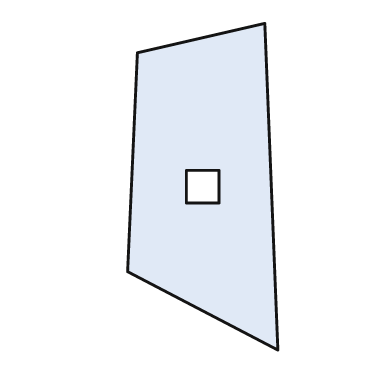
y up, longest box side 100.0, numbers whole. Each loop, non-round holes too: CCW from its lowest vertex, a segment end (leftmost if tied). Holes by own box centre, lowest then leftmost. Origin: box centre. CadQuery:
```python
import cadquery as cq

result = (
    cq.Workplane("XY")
    .moveTo(23.0, -50.0)
    .lineTo(19.0, 50.0)
    .lineTo(-20.0, 41.0)
    .lineTo(-23.0, -26.0)
    .close()
    .moveTo(-5.0, -5.0)
    .lineTo(5.0, -5.0)
    .lineTo(5.0, 5.0)
    .lineTo(-5.0, 5.0)
    .close()
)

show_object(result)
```